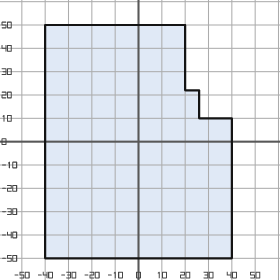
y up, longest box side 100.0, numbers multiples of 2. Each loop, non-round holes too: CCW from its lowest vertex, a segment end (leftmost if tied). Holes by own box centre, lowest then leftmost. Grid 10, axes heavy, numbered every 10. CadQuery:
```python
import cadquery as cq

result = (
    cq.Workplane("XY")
    .moveTo(-40.0, -50.0)
    .lineTo(40.0, -50.0)
    .lineTo(40.0, 10.0)
    .lineTo(26.0, 10.0)
    .lineTo(26.0, 22.0)
    .lineTo(20.0, 22.0)
    .lineTo(20.0, 50.0)
    .lineTo(-40.0, 50.0)
    .close()
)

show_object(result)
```